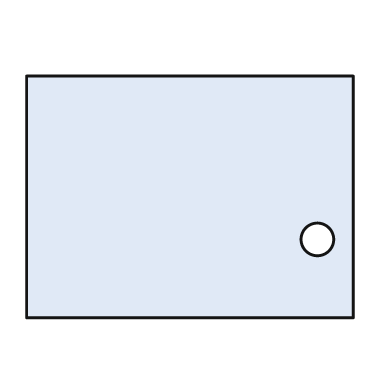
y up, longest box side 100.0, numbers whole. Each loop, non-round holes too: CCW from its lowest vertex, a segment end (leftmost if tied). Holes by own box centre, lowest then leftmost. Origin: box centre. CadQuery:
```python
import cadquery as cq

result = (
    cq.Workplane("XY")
    .moveTo(-50.0, -37.0)
    .lineTo(50.0, -37.0)
    .lineTo(50.0, 37.0)
    .lineTo(-50.0, 37.0)
    .close()
    .moveTo(39.0, -13.0)
    .circle(5.0)
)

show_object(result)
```